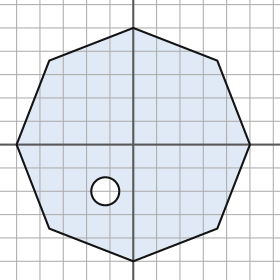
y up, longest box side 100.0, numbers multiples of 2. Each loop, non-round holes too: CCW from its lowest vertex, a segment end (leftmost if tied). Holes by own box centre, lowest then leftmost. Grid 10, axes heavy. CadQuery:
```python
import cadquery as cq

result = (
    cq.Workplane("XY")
    .moveTo(0.0, -50.0)
    .lineTo(36.0, -36.0)
    .lineTo(50.0, 0.0)
    .lineTo(36.0, 36.0)
    .lineTo(0.0, 50.0)
    .lineTo(-36.0, 36.0)
    .lineTo(-50.0, 0.0)
    .lineTo(-36.0, -36.0)
    .close()
    .moveTo(-12.0, -20.0)
    .circle(6.0)
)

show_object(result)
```